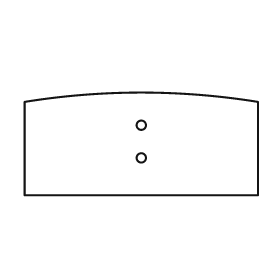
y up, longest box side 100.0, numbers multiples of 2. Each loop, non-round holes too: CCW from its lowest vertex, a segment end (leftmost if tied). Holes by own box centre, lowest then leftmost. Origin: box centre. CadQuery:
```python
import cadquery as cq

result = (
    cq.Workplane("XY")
    .moveTo(-50.0, -22.0)
    .lineTo(50.0, -22.0)
    .lineTo(50.0, 18.0)
    .threePointArc((0.0, 22.0), (-50.0, 18.0))
    .close()
    .moveTo(0.0, -6.0)
    .circle(2.0)
    .moveTo(0.0, 8.0)
    .circle(2.0)
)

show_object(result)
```